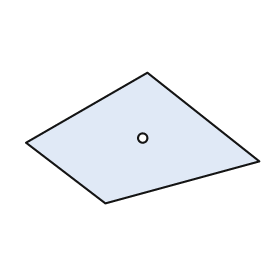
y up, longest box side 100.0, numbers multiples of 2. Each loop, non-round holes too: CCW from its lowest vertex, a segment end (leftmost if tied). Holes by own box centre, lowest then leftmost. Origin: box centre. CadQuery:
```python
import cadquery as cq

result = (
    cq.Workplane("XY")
    .moveTo(-16.0, -28.0)
    .lineTo(50.0, -10.0)
    .lineTo(2.0, 28.0)
    .lineTo(-50.0, -2.0)
    .close()
    .moveTo(0.0, 0.0)
    .circle(2.0)
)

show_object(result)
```